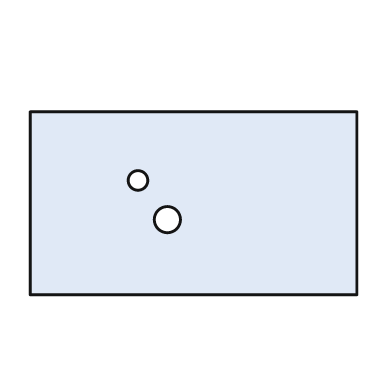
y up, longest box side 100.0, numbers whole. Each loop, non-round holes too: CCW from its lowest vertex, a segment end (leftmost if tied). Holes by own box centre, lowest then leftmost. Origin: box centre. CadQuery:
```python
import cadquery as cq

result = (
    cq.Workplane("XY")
    .moveTo(-50.0, -28.0)
    .lineTo(50.0, -28.0)
    .lineTo(50.0, 28.0)
    .lineTo(-50.0, 28.0)
    .close()
    .moveTo(-8.0, -5.0)
    .circle(4.0)
    .moveTo(-17.0, 7.0)
    .circle(3.0)
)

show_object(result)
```